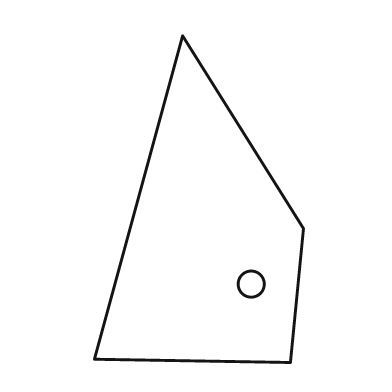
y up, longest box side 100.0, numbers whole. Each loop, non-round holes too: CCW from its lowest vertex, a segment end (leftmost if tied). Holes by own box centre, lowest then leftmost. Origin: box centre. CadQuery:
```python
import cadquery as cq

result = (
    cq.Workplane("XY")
    .moveTo(28.0, -50.0)
    .lineTo(32.0, -9.0)
    .lineTo(-5.0, 50.0)
    .lineTo(-32.0, -49.0)
    .close()
    .moveTo(16.0, -26.0)
    .circle(4.0)
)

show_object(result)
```